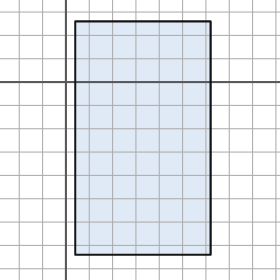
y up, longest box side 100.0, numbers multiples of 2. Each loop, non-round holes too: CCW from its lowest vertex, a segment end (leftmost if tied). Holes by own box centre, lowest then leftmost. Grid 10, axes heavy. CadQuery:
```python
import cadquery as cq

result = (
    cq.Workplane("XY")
    .moveTo(4.0, -74.0)
    .lineTo(62.0, -74.0)
    .lineTo(62.0, 26.0)
    .lineTo(4.0, 26.0)
    .close()
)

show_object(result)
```